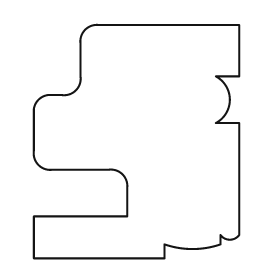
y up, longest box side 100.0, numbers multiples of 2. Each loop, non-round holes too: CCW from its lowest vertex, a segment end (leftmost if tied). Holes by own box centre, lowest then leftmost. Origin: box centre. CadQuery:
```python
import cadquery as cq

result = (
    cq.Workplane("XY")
    .moveTo(-44.0, -50.0)
    .lineTo(12.0, -50.0)
    .lineTo(12.0, -44.0)
    .threePointArc((24.0, -46.0), (36.0, -44.0))
    .lineTo(36.0, -40.0)
    .threePointArc((40.0, -42.0), (44.0, -40.0))
    .lineTo(44.0, 8.0)
    .lineTo(34.0, 8.0)
    .threePointArc((40.0, 18.0), (34.0, 28.0))
    .lineTo(44.0, 28.0)
    .lineTo(44.0, 50.0)
    .lineTo(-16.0, 50.0)
    .threePointArc((-22.0, 48.0), (-24.0, 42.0))
    .lineTo(-24.0, 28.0)
    .threePointArc((-26.0, 22.0), (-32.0, 20.0))
    .lineTo(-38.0, 20.0)
    .threePointArc((-42.0, 18.0), (-44.0, 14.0))
    .lineTo(-44.0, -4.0)
    .threePointArc((-42.0, -10.0), (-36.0, -12.0))
    .lineTo(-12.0, -12.0)
    .threePointArc((-6.0, -14.0), (-4.0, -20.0))
    .lineTo(-4.0, -32.0)
    .lineTo(-44.0, -32.0)
    .close()
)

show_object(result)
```